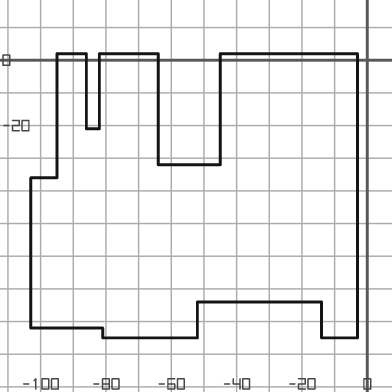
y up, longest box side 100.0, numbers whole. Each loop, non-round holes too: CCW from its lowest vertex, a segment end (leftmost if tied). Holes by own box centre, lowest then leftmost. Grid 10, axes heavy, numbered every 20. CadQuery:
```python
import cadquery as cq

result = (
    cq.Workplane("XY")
    .moveTo(-81.0, -85.0)
    .lineTo(-52.0, -85.0)
    .lineTo(-52.0, -74.0)
    .lineTo(-14.0, -74.0)
    .lineTo(-14.0, -85.0)
    .lineTo(-3.0, -85.0)
    .lineTo(-3.0, 2.0)
    .lineTo(-45.0, 2.0)
    .lineTo(-45.0, -32.0)
    .lineTo(-64.0, -32.0)
    .lineTo(-64.0, 2.0)
    .lineTo(-82.0, 2.0)
    .lineTo(-82.0, -21.0)
    .lineTo(-86.0, -21.0)
    .lineTo(-86.0, 2.0)
    .lineTo(-95.0, 2.0)
    .lineTo(-95.0, -36.0)
    .lineTo(-103.0, -36.0)
    .lineTo(-103.0, -82.0)
    .lineTo(-81.0, -82.0)
    .close()
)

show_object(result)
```